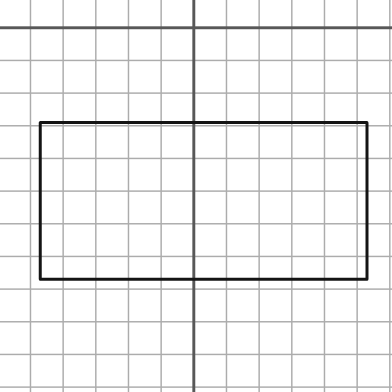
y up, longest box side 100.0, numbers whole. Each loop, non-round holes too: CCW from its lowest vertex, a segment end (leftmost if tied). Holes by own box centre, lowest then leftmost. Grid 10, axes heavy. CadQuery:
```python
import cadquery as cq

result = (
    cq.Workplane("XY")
    .moveTo(-47.0, -77.0)
    .lineTo(53.0, -77.0)
    .lineTo(53.0, -29.0)
    .lineTo(-47.0, -29.0)
    .close()
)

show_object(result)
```